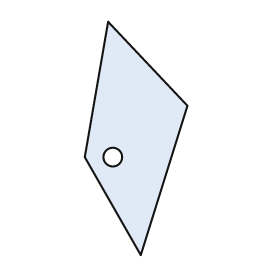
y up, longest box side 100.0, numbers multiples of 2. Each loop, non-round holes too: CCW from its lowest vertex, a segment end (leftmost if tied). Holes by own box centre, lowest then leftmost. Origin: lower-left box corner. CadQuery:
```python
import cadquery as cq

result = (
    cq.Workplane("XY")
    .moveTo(24.0, 0.0)
    .lineTo(44.0, 64.0)
    .lineTo(10.0, 100.0)
    .lineTo(0.0, 42.0)
    .close()
    .moveTo(12.0, 42.0)
    .circle(4.0)
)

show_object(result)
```